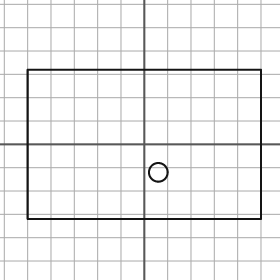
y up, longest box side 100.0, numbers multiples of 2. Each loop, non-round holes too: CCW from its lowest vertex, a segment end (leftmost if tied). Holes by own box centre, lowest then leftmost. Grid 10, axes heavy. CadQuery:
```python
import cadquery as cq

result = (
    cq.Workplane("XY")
    .moveTo(-50.0, -32.0)
    .lineTo(50.0, -32.0)
    .lineTo(50.0, 32.0)
    .lineTo(-50.0, 32.0)
    .close()
    .moveTo(6.0, -12.0)
    .circle(4.0)
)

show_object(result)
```